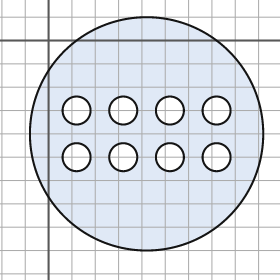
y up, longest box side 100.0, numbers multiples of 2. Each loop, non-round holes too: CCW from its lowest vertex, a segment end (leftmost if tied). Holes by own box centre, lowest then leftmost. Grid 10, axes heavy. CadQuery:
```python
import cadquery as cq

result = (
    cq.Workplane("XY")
    .moveTo(42.0, -40.0)
    .circle(50.0)
    .moveTo(12.0, -50.0)
    .circle(6.0)
    .moveTo(32.0, -50.0)
    .circle(6.0)
    .moveTo(52.0, -50.0)
    .circle(6.0)
    .moveTo(72.0, -50.0)
    .circle(6.0)
    .moveTo(12.0, -30.0)
    .circle(6.0)
    .moveTo(32.0, -30.0)
    .circle(6.0)
    .moveTo(52.0, -30.0)
    .circle(6.0)
    .moveTo(72.0, -30.0)
    .circle(6.0)
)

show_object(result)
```